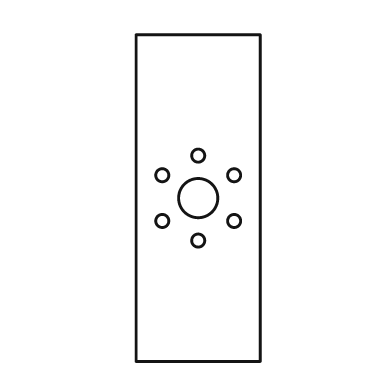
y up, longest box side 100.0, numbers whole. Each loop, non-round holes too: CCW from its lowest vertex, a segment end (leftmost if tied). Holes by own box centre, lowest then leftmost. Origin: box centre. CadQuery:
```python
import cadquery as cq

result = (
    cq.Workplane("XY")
    .moveTo(-19.0, -50.0)
    .lineTo(19.0, -50.0)
    .lineTo(19.0, 50.0)
    .lineTo(-19.0, 50.0)
    .close()
    .moveTo(0.0, -13.0)
    .circle(2.0)
    .moveTo(-11.0, -7.0)
    .circle(2.0)
    .moveTo(11.0, -7.0)
    .circle(2.0)
    .moveTo(0.0, 0.0)
    .circle(6.0)
    .moveTo(-11.0, 7.0)
    .circle(2.0)
    .moveTo(11.0, 7.0)
    .circle(2.0)
    .moveTo(0.0, 13.0)
    .circle(2.0)
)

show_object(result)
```